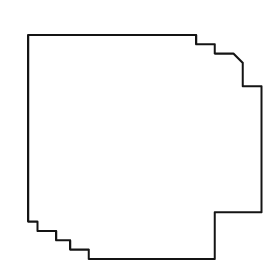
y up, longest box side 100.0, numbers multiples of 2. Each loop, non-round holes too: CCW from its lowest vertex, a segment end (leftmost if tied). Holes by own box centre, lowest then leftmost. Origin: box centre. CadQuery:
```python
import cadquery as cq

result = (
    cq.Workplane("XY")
    .moveTo(-24.0, -48.0)
    .lineTo(30.0, -48.0)
    .lineTo(30.0, -28.0)
    .lineTo(50.0, -28.0)
    .lineTo(50.0, 26.0)
    .lineTo(42.0, 26.0)
    .lineTo(42.0, 36.0)
    .lineTo(38.0, 40.0)
    .lineTo(30.0, 40.0)
    .lineTo(30.0, 44.0)
    .lineTo(22.0, 44.0)
    .lineTo(22.0, 48.0)
    .lineTo(-50.0, 48.0)
    .lineTo(-50.0, -32.0)
    .lineTo(-46.0, -32.0)
    .lineTo(-46.0, -36.0)
    .lineTo(-38.0, -36.0)
    .lineTo(-38.0, -40.0)
    .lineTo(-32.0, -40.0)
    .lineTo(-32.0, -44.0)
    .lineTo(-24.0, -44.0)
    .close()
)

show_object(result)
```